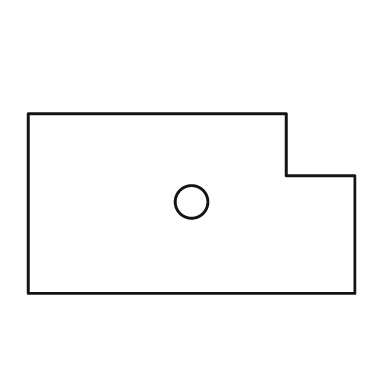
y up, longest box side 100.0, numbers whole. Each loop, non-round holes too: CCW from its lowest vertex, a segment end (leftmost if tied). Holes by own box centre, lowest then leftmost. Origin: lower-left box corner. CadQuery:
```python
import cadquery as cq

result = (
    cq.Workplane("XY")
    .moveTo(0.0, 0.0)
    .lineTo(100.0, 0.0)
    .lineTo(100.0, 36.0)
    .lineTo(79.0, 36.0)
    .lineTo(79.0, 55.0)
    .lineTo(0.0, 55.0)
    .close()
    .moveTo(50.0, 28.0)
    .circle(5.0)
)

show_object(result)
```